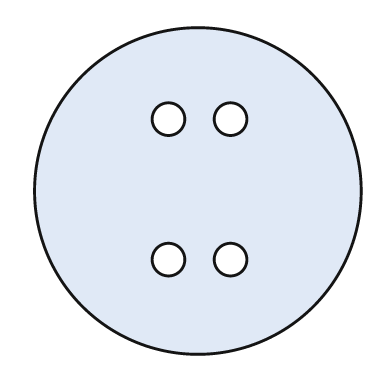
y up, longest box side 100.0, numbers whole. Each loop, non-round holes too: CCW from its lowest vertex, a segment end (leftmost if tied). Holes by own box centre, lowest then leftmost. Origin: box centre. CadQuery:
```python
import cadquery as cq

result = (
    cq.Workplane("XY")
    .moveTo(0.0, 0.0)
    .circle(50.0)
    .moveTo(-9.0, -21.0)
    .circle(5.0)
    .moveTo(10.0, -21.0)
    .circle(5.0)
    .moveTo(-9.0, 22.0)
    .circle(5.0)
    .moveTo(10.0, 22.0)
    .circle(5.0)
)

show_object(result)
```